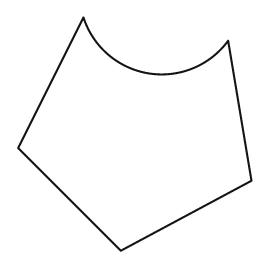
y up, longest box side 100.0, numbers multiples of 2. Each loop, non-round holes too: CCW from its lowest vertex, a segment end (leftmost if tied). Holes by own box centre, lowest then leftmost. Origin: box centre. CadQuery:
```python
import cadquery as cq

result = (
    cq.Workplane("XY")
    .moveTo(-6.0, -50.0)
    .lineTo(50.0, -20.0)
    .lineTo(40.0, 40.0)
    .threePointArc((6.0, 26.0), (-22.0, 50.0))
    .lineTo(-50.0, -6.0)
    .close()
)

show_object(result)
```